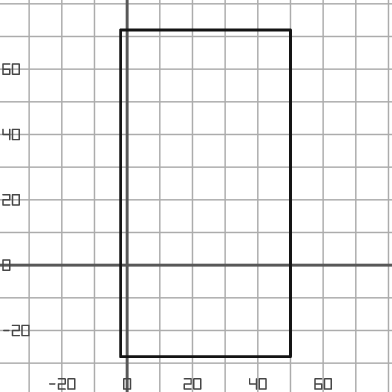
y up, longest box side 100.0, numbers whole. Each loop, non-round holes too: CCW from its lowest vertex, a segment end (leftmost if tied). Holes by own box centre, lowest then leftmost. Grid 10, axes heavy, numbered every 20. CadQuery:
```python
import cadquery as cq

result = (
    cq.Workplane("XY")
    .moveTo(-2.0, -28.0)
    .lineTo(50.0, -28.0)
    .lineTo(50.0, 72.0)
    .lineTo(-2.0, 72.0)
    .close()
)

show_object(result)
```